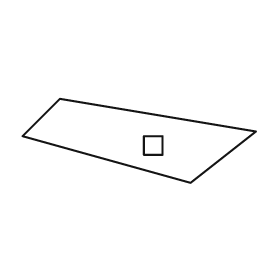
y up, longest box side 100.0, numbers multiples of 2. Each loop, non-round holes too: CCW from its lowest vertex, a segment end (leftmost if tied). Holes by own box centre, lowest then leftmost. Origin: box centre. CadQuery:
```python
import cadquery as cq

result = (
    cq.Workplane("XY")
    .moveTo(22.0, -18.0)
    .lineTo(50.0, 4.0)
    .lineTo(-34.0, 18.0)
    .lineTo(-50.0, 2.0)
    .close()
    .moveTo(2.0, -6.0)
    .lineTo(10.0, -6.0)
    .lineTo(10.0, 2.0)
    .lineTo(2.0, 2.0)
    .close()
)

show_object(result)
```